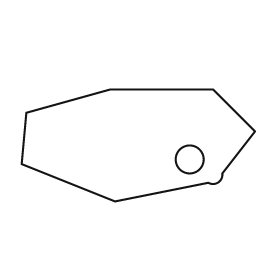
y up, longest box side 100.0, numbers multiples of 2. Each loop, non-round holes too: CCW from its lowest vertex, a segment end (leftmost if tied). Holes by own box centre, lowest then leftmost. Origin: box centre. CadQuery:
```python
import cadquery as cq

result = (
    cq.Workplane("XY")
    .moveTo(-10.0, -24.0)
    .lineTo(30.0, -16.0)
    .threePointArc((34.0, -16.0), (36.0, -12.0))
    .lineTo(50.0, 6.0)
    .lineTo(32.0, 24.0)
    .lineTo(-12.0, 24.0)
    .lineTo(-48.0, 14.0)
    .lineTo(-50.0, -8.0)
    .close()
    .moveTo(22.0, -6.0)
    .circle(6.0)
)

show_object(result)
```